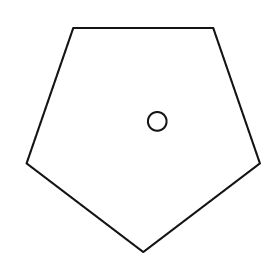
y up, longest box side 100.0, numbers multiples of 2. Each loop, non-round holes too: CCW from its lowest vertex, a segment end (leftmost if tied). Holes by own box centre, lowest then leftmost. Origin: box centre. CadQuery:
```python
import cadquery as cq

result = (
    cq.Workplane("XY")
    .moveTo(0.0, -48.0)
    .lineTo(50.0, -10.0)
    .lineTo(30.0, 48.0)
    .lineTo(-30.0, 48.0)
    .lineTo(-50.0, -10.0)
    .close()
    .moveTo(6.0, 8.0)
    .circle(4.0)
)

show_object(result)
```